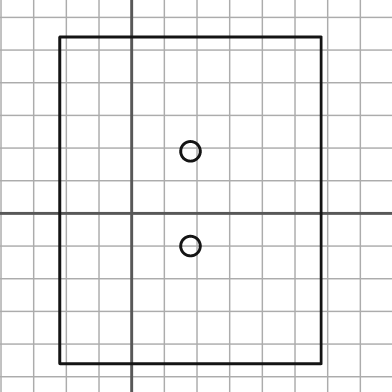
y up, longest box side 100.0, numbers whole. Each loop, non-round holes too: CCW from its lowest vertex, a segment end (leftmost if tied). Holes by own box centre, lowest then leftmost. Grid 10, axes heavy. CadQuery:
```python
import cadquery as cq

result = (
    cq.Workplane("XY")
    .moveTo(-22.0, -46.0)
    .lineTo(58.0, -46.0)
    .lineTo(58.0, 54.0)
    .lineTo(-22.0, 54.0)
    .close()
    .moveTo(18.0, -10.0)
    .circle(3.0)
    .moveTo(18.0, 19.0)
    .circle(3.0)
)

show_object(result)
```